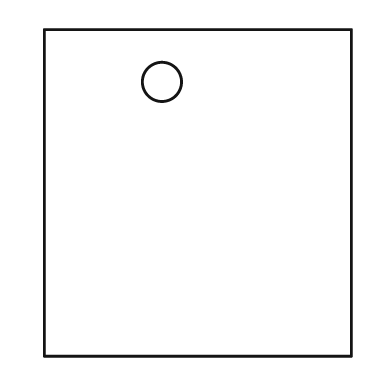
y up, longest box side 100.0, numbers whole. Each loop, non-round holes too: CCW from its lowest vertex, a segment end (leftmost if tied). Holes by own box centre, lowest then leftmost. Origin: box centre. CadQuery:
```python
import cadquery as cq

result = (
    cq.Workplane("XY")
    .moveTo(-47.0, -50.0)
    .lineTo(47.0, -50.0)
    .lineTo(47.0, 50.0)
    .lineTo(-47.0, 50.0)
    .close()
    .moveTo(-11.0, 34.0)
    .circle(6.0)
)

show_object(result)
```